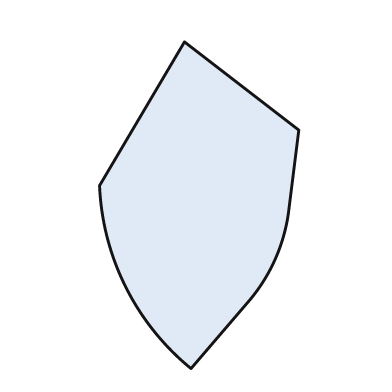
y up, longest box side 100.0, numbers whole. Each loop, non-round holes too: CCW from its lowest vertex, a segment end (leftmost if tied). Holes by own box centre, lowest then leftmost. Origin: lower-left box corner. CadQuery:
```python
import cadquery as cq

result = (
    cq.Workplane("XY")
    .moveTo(28.0, 0.0)
    .lineTo(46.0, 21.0)
    .threePointArc((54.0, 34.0), (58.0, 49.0))
    .lineTo(61.0, 73.0)
    .lineTo(26.0, 100.0)
    .lineTo(0.0, 56.0)
    .threePointArc((8.0, 25.0), (28.0, 0.0))
    .close()
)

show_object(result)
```